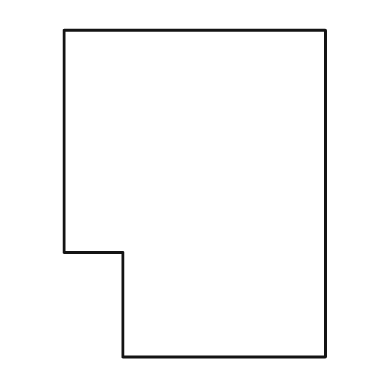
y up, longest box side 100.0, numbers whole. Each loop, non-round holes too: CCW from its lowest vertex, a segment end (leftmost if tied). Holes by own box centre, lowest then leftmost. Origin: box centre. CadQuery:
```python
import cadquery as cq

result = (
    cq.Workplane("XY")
    .moveTo(-22.0, -50.0)
    .lineTo(40.0, -50.0)
    .lineTo(40.0, 50.0)
    .lineTo(-40.0, 50.0)
    .lineTo(-40.0, -18.0)
    .lineTo(-22.0, -18.0)
    .close()
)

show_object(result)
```